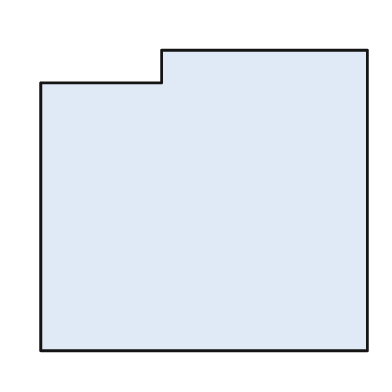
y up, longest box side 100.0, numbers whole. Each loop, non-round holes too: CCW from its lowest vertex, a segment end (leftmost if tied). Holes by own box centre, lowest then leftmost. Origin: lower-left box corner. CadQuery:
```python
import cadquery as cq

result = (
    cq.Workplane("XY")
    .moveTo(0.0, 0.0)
    .lineTo(100.0, 0.0)
    .lineTo(100.0, 92.0)
    .lineTo(37.0, 92.0)
    .lineTo(37.0, 82.0)
    .lineTo(0.0, 82.0)
    .close()
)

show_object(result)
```